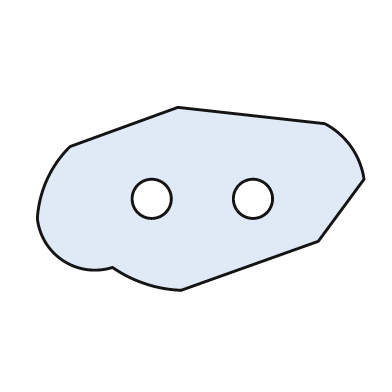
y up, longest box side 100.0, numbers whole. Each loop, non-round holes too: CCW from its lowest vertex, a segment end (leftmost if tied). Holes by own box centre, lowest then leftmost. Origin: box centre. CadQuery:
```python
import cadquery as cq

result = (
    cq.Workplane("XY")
    .moveTo(-6.0, -28.0)
    .lineTo(36.0, -13.0)
    .lineTo(50.0, 6.0)
    .threePointArc((46.0, 16.0), (38.0, 23.0))
    .lineTo(-7.0, 28.0)
    .lineTo(-40.0, 16.0)
    .threePointArc((-47.0, 6.0), (-50.0, -6.0))
    .threePointArc((-42.0, -19.0), (-27.0, -21.0))
    .threePointArc((-17.0, -26.0), (-6.0, -28.0))
    .close()
    .moveTo(-15.0, 0.0)
    .circle(6.0)
    .moveTo(16.0, 0.0)
    .circle(6.0)
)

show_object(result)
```